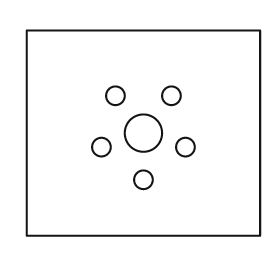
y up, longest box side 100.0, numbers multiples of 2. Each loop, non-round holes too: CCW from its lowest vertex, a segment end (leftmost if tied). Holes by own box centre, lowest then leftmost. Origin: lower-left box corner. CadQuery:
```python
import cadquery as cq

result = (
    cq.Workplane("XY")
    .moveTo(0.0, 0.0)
    .lineTo(100.0, 0.0)
    .lineTo(100.0, 88.0)
    .lineTo(0.0, 88.0)
    .close()
    .moveTo(50.0, 24.0)
    .circle(4.0)
    .moveTo(32.0, 38.0)
    .circle(4.0)
    .moveTo(68.0, 38.0)
    .circle(4.0)
    .moveTo(50.0, 44.0)
    .circle(8.0)
    .moveTo(38.0, 60.0)
    .circle(4.0)
    .moveTo(62.0, 60.0)
    .circle(4.0)
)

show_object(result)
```